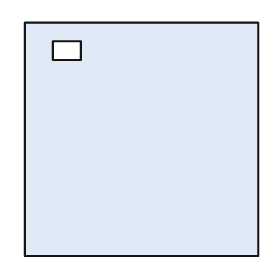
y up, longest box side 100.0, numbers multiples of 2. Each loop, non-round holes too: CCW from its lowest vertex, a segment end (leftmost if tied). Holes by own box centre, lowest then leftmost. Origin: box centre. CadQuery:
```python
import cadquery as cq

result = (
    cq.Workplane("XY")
    .moveTo(-50.0, -50.0)
    .lineTo(50.0, -50.0)
    .lineTo(50.0, 50.0)
    .lineTo(-50.0, 50.0)
    .close()
    .moveTo(-38.0, 34.0)
    .lineTo(-26.0, 34.0)
    .lineTo(-26.0, 42.0)
    .lineTo(-38.0, 42.0)
    .close()
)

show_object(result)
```